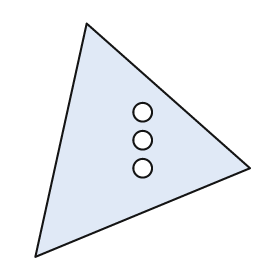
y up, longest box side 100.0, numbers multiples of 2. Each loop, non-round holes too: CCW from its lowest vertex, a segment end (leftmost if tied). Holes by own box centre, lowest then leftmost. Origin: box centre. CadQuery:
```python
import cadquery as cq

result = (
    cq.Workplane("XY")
    .moveTo(-46.0, -50.0)
    .lineTo(46.0, -12.0)
    .lineTo(-24.0, 50.0)
    .close()
    .moveTo(0.0, -12.0)
    .circle(4.0)
    .moveTo(0.0, 0.0)
    .circle(4.0)
    .moveTo(0.0, 12.0)
    .circle(4.0)
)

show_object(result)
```